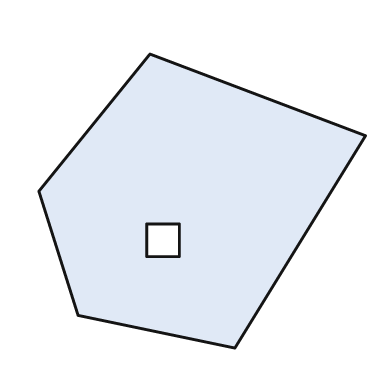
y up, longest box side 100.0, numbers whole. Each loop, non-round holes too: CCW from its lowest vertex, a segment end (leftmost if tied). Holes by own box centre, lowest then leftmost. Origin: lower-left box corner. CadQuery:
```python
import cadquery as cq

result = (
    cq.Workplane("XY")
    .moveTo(60.0, 0.0)
    .lineTo(100.0, 65.0)
    .lineTo(34.0, 90.0)
    .lineTo(0.0, 48.0)
    .lineTo(12.0, 10.0)
    .close()
    .moveTo(33.0, 28.0)
    .lineTo(43.0, 28.0)
    .lineTo(43.0, 38.0)
    .lineTo(33.0, 38.0)
    .close()
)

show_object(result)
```